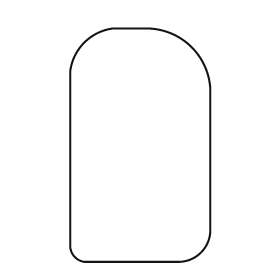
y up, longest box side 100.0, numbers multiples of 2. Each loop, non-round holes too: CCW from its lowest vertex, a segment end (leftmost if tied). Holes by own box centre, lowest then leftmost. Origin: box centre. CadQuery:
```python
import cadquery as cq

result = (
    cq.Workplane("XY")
    .moveTo(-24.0, -50.0)
    .lineTo(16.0, -50.0)
    .threePointArc((26.0, -46.0), (30.0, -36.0))
    .lineTo(30.0, 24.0)
    .threePointArc((22.0, 42.0), (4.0, 50.0))
    .lineTo(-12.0, 50.0)
    .threePointArc((-24.0, 44.0), (-30.0, 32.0))
    .lineTo(-30.0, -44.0)
    .threePointArc((-28.0, -48.0), (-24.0, -50.0))
    .close()
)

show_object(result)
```